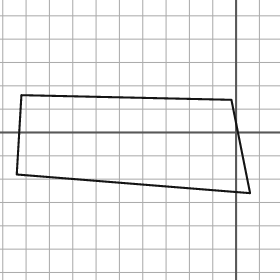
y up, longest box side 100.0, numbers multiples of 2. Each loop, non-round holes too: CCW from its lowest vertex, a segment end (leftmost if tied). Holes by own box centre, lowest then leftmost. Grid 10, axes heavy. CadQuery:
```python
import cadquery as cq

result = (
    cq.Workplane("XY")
    .moveTo(6.0, -26.0)
    .lineTo(-2.0, 14.0)
    .lineTo(-92.0, 16.0)
    .lineTo(-94.0, -18.0)
    .close()
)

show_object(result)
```